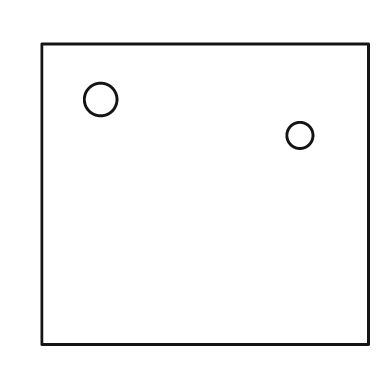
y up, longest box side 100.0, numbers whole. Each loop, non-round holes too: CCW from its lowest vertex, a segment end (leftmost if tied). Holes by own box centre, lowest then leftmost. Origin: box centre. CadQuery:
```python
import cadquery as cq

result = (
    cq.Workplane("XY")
    .moveTo(-50.0, -46.0)
    .lineTo(50.0, -46.0)
    .lineTo(50.0, 46.0)
    .lineTo(-50.0, 46.0)
    .close()
    .moveTo(29.0, 18.0)
    .circle(4.0)
    .moveTo(-32.0, 29.0)
    .circle(5.0)
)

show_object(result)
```